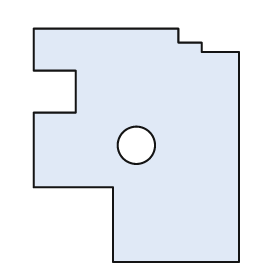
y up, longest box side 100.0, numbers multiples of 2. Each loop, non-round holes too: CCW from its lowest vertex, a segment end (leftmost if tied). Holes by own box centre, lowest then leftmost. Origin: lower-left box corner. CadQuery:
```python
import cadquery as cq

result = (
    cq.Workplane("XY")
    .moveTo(34.0, 0.0)
    .lineTo(88.0, 0.0)
    .lineTo(88.0, 90.0)
    .lineTo(72.0, 90.0)
    .lineTo(72.0, 94.0)
    .lineTo(62.0, 94.0)
    .lineTo(62.0, 100.0)
    .lineTo(0.0, 100.0)
    .lineTo(0.0, 82.0)
    .lineTo(18.0, 82.0)
    .lineTo(18.0, 64.0)
    .lineTo(0.0, 64.0)
    .lineTo(0.0, 32.0)
    .lineTo(34.0, 32.0)
    .close()
    .moveTo(44.0, 50.0)
    .circle(8.0)
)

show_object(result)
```